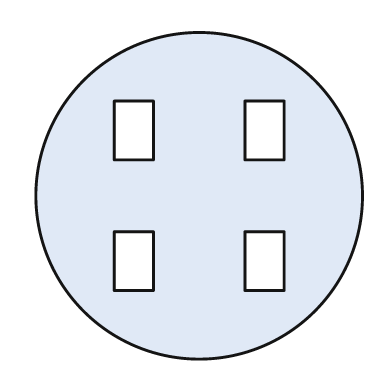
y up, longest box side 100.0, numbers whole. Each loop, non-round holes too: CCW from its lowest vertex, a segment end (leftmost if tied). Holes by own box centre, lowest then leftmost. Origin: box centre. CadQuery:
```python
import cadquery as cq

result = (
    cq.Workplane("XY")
    .moveTo(0.0, 0.0)
    .circle(50.0)
    .moveTo(-26.0, -29.0)
    .lineTo(-14.0, -29.0)
    .lineTo(-14.0, -11.0)
    .lineTo(-26.0, -11.0)
    .close()
    .moveTo(14.0, -29.0)
    .lineTo(26.0, -29.0)
    .lineTo(26.0, -11.0)
    .lineTo(14.0, -11.0)
    .close()
    .moveTo(-26.0, 11.0)
    .lineTo(-14.0, 11.0)
    .lineTo(-14.0, 29.0)
    .lineTo(-26.0, 29.0)
    .close()
    .moveTo(14.0, 11.0)
    .lineTo(26.0, 11.0)
    .lineTo(26.0, 29.0)
    .lineTo(14.0, 29.0)
    .close()
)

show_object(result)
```